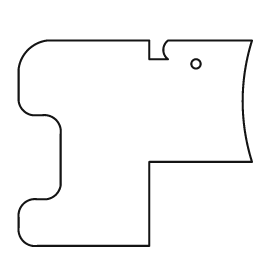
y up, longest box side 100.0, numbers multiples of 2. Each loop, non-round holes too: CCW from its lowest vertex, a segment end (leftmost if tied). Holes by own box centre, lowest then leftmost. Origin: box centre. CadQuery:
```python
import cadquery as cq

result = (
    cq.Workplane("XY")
    .moveTo(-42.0, -44.0)
    .lineTo(6.0, -44.0)
    .lineTo(6.0, -8.0)
    .lineTo(50.0, -8.0)
    .threePointArc((46.0, 18.0), (50.0, 44.0))
    .lineTo(14.0, 44.0)
    .threePointArc((12.0, 40.0), (14.0, 36.0))
    .lineTo(6.0, 36.0)
    .lineTo(6.0, 44.0)
    .lineTo(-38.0, 44.0)
    .threePointArc((-46.0, 40.0), (-50.0, 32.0))
    .lineTo(-50.0, 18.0)
    .threePointArc((-48.0, 14.0), (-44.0, 12.0))
    .lineTo(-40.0, 12.0)
    .threePointArc((-34.0, 10.0), (-32.0, 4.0))
    .lineTo(-32.0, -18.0)
    .threePointArc((-34.0, -22.0), (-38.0, -24.0))
    .lineTo(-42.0, -24.0)
    .threePointArc((-48.0, -26.0), (-50.0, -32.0))
    .lineTo(-50.0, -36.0)
    .threePointArc((-48.0, -42.0), (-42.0, -44.0))
    .close()
    .moveTo(26.0, 34.0)
    .circle(2.0)
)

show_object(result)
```